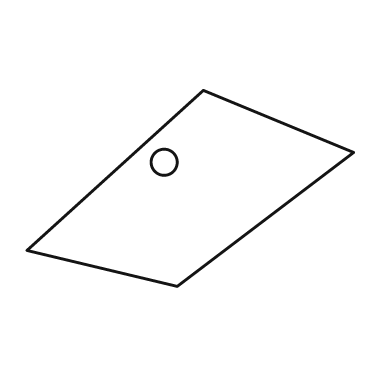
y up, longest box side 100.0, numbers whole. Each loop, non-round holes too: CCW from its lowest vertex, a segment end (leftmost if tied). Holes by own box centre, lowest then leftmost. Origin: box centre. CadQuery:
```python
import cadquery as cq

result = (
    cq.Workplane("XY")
    .moveTo(-4.0, -30.0)
    .lineTo(50.0, 11.0)
    .lineTo(4.0, 30.0)
    .lineTo(-50.0, -19.0)
    .close()
    .moveTo(-8.0, 8.0)
    .circle(4.0)
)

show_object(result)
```